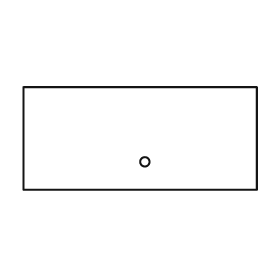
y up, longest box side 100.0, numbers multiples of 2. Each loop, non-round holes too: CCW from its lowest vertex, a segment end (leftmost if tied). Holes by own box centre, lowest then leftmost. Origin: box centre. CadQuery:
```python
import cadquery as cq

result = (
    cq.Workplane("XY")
    .moveTo(-50.0, -22.0)
    .lineTo(50.0, -22.0)
    .lineTo(50.0, 22.0)
    .lineTo(-50.0, 22.0)
    .close()
    .moveTo(2.0, -10.0)
    .circle(2.0)
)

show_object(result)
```